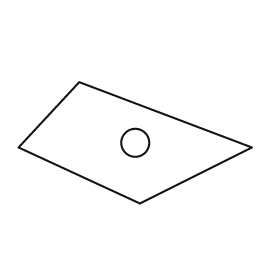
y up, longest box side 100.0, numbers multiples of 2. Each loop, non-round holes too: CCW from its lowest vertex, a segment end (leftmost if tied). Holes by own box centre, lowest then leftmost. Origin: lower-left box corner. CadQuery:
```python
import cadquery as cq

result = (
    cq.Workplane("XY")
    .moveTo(52.0, 0.0)
    .lineTo(100.0, 24.0)
    .lineTo(26.0, 52.0)
    .lineTo(0.0, 24.0)
    .close()
    .moveTo(50.0, 26.0)
    .circle(6.0)
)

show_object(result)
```